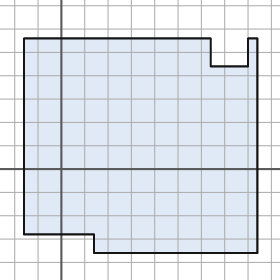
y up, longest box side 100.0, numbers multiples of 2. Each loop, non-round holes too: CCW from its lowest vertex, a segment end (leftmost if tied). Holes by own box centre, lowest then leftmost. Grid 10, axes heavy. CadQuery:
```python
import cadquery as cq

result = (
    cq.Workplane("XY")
    .moveTo(14.0, -36.0)
    .lineTo(84.0, -36.0)
    .lineTo(84.0, 56.0)
    .lineTo(80.0, 56.0)
    .lineTo(80.0, 44.0)
    .lineTo(64.0, 44.0)
    .lineTo(64.0, 56.0)
    .lineTo(-16.0, 56.0)
    .lineTo(-16.0, -28.0)
    .lineTo(14.0, -28.0)
    .close()
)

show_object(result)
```